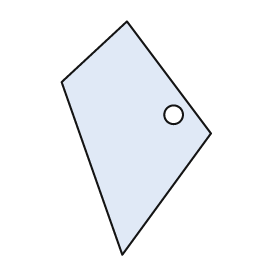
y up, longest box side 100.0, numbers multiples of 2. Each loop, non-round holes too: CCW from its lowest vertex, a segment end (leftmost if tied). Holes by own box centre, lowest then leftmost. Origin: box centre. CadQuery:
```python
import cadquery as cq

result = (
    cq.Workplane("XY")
    .moveTo(-6.0, -50.0)
    .lineTo(32.0, 2.0)
    .lineTo(-4.0, 50.0)
    .lineTo(-32.0, 24.0)
    .close()
    .moveTo(16.0, 10.0)
    .circle(4.0)
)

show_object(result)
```